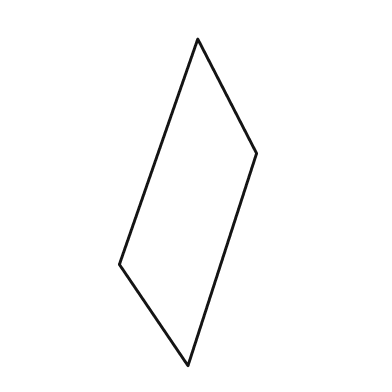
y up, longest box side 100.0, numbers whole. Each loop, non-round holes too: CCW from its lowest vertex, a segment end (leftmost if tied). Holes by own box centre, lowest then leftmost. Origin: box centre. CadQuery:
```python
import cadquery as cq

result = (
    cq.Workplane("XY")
    .moveTo(0.0, -50.0)
    .lineTo(21.0, 15.0)
    .lineTo(3.0, 50.0)
    .lineTo(-21.0, -19.0)
    .close()
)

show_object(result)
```